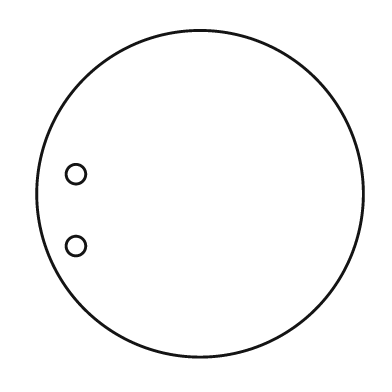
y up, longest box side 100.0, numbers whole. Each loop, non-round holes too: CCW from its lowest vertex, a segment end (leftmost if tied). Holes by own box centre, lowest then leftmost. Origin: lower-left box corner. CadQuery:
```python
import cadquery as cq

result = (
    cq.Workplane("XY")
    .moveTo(50.0, 50.0)
    .circle(50.0)
    .moveTo(12.0, 34.0)
    .circle(3.0)
    .moveTo(12.0, 56.0)
    .circle(3.0)
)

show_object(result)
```